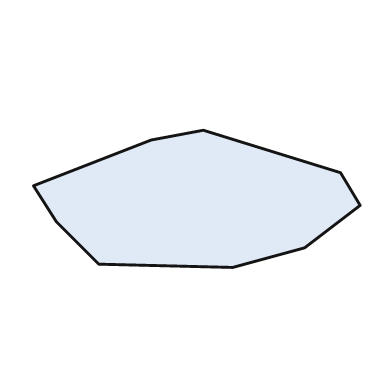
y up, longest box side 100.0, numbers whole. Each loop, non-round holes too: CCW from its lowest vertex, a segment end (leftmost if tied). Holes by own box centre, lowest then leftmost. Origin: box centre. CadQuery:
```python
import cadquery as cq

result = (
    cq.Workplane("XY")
    .moveTo(11.0, -21.0)
    .lineTo(33.0, -15.0)
    .lineTo(50.0, -2.0)
    .lineTo(44.0, 8.0)
    .lineTo(2.0, 21.0)
    .lineTo(-14.0, 18.0)
    .lineTo(-50.0, 4.0)
    .lineTo(-43.0, -7.0)
    .lineTo(-30.0, -20.0)
    .close()
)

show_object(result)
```